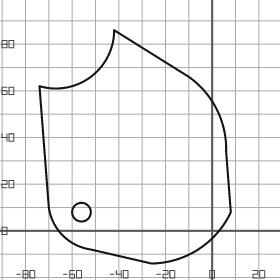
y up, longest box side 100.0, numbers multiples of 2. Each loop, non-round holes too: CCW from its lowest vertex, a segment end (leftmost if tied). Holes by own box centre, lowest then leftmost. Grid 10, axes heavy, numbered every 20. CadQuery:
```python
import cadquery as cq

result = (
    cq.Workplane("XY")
    .moveTo(-26.0, -14.0)
    .threePointArc((-6.0, -8.0), (8.0, 8.0))
    .lineTo(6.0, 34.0)
    .threePointArc((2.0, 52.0), (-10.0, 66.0))
    .lineTo(-42.0, 86.0)
    .threePointArc((-52.0, 66.0), (-74.0, 62.0))
    .lineTo(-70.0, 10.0)
    .threePointArc((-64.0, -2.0), (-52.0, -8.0))
    .close()
    .moveTo(-56.0, 8.0)
    .circle(4.0)
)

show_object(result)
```